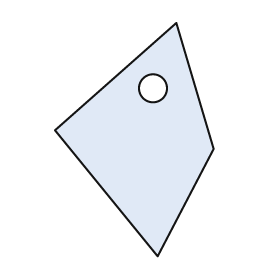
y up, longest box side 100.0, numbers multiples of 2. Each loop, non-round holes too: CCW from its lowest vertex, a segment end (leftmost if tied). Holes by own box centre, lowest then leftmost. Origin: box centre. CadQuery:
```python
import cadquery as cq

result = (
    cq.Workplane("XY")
    .moveTo(10.0, -50.0)
    .lineTo(34.0, -4.0)
    .lineTo(18.0, 50.0)
    .lineTo(-34.0, 4.0)
    .close()
    .moveTo(8.0, 22.0)
    .circle(6.0)
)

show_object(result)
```